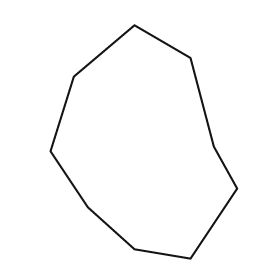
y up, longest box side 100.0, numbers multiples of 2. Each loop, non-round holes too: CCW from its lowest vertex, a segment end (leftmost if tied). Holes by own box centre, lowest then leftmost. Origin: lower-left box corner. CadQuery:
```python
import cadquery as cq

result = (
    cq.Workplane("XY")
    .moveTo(60.0, 0.0)
    .lineTo(80.0, 30.0)
    .lineTo(70.0, 48.0)
    .lineTo(60.0, 86.0)
    .lineTo(36.0, 100.0)
    .lineTo(10.0, 78.0)
    .lineTo(0.0, 46.0)
    .lineTo(16.0, 22.0)
    .lineTo(36.0, 4.0)
    .close()
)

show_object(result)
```